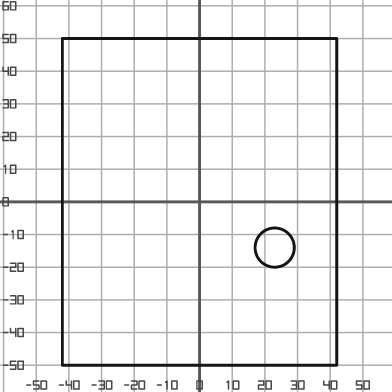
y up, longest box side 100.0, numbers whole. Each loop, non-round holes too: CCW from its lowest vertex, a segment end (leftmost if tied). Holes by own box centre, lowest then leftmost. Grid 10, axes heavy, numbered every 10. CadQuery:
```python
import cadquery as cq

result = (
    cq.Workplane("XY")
    .moveTo(-42.0, -50.0)
    .lineTo(42.0, -50.0)
    .lineTo(42.0, 50.0)
    .lineTo(-42.0, 50.0)
    .close()
    .moveTo(23.0, -14.0)
    .circle(6.0)
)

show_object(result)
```